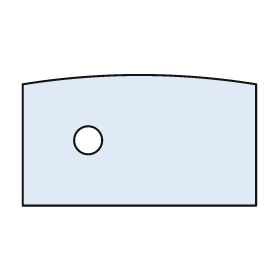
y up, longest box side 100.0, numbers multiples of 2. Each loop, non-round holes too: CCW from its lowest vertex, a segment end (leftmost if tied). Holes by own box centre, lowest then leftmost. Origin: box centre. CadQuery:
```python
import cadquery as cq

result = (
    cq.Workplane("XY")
    .moveTo(-50.0, -28.0)
    .lineTo(50.0, -28.0)
    .lineTo(50.0, 24.0)
    .threePointArc((0.0, 28.0), (-50.0, 24.0))
    .close()
    .moveTo(-22.0, 0.0)
    .circle(6.0)
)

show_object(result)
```